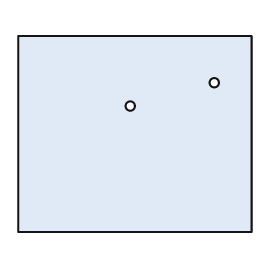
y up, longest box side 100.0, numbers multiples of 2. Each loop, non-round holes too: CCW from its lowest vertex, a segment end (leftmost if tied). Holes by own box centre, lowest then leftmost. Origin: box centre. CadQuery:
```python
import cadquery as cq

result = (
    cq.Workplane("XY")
    .moveTo(-50.0, -42.0)
    .lineTo(50.0, -42.0)
    .lineTo(50.0, 42.0)
    .lineTo(-50.0, 42.0)
    .close()
    .moveTo(-2.0, 12.0)
    .circle(2.0)
    .moveTo(34.0, 22.0)
    .circle(2.0)
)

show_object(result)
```